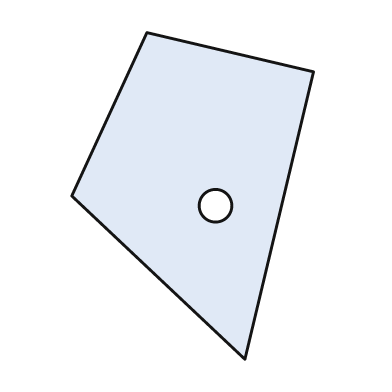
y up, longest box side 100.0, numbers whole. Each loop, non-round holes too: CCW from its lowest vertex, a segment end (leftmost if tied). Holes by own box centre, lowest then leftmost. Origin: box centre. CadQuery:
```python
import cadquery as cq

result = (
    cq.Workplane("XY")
    .moveTo(16.0, -50.0)
    .lineTo(37.0, 38.0)
    .lineTo(-14.0, 50.0)
    .lineTo(-37.0, 0.0)
    .close()
    .moveTo(7.0, -3.0)
    .circle(5.0)
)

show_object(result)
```